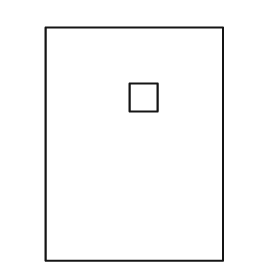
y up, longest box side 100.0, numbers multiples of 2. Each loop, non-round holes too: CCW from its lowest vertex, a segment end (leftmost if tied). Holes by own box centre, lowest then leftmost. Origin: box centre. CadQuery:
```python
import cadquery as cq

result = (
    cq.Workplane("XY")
    .moveTo(-38.0, -50.0)
    .lineTo(38.0, -50.0)
    .lineTo(38.0, 50.0)
    .lineTo(-38.0, 50.0)
    .close()
    .moveTo(-2.0, 14.0)
    .lineTo(10.0, 14.0)
    .lineTo(10.0, 26.0)
    .lineTo(-2.0, 26.0)
    .close()
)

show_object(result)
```